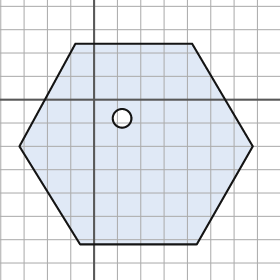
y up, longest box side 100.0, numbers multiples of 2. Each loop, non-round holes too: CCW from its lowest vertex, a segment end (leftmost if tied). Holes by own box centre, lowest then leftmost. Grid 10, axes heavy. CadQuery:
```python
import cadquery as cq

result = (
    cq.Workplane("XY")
    .moveTo(-6.0, -62.0)
    .lineTo(44.0, -62.0)
    .lineTo(68.0, -20.0)
    .lineTo(42.0, 24.0)
    .lineTo(-8.0, 24.0)
    .lineTo(-32.0, -20.0)
    .close()
    .moveTo(12.0, -8.0)
    .circle(4.0)
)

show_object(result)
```